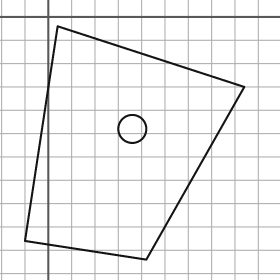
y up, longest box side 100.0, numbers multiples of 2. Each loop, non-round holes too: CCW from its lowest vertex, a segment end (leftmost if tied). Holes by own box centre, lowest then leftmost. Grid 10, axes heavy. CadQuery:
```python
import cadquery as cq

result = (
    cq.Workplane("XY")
    .moveTo(42.0, -104.0)
    .lineTo(84.0, -30.0)
    .lineTo(4.0, -4.0)
    .lineTo(-10.0, -96.0)
    .close()
    .moveTo(36.0, -48.0)
    .circle(6.0)
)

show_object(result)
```